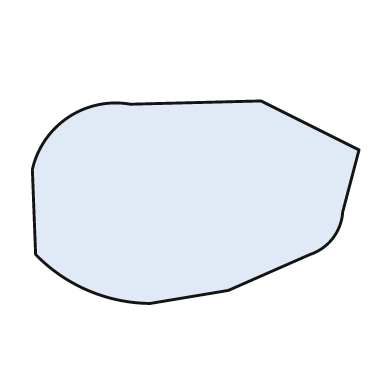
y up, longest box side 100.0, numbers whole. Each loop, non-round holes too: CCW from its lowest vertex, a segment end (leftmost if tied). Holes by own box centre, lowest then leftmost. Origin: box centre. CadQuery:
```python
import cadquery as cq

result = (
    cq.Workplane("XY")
    .moveTo(-14.0, -31.0)
    .lineTo(10.0, -27.0)
    .lineTo(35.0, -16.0)
    .threePointArc((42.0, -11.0), (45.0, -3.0))
    .lineTo(50.0, 16.0)
    .lineTo(20.0, 31.0)
    .lineTo(-20.0, 30.0)
    .threePointArc((-39.0, 26.0), (-50.0, 10.0))
    .lineTo(-49.0, -16.0)
    .threePointArc((-33.0, -27.0), (-14.0, -31.0))
    .close()
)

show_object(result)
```